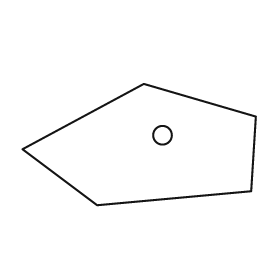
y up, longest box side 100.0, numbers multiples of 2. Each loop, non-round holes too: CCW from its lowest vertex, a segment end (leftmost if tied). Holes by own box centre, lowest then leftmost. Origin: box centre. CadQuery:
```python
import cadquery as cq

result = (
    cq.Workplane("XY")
    .moveTo(-18.0, -26.0)
    .lineTo(48.0, -20.0)
    .lineTo(50.0, 12.0)
    .lineTo(2.0, 26.0)
    .lineTo(-50.0, -2.0)
    .close()
    .moveTo(10.0, 4.0)
    .circle(4.0)
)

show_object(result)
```